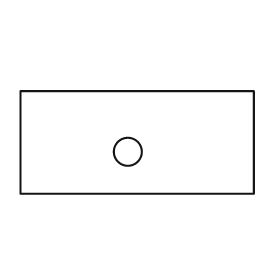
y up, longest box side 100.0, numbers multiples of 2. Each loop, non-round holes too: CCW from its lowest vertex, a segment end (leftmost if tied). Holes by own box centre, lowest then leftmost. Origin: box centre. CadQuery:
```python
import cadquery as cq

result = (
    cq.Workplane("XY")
    .moveTo(-50.0, -22.0)
    .lineTo(50.0, -22.0)
    .lineTo(50.0, 22.0)
    .lineTo(-50.0, 22.0)
    .close()
    .moveTo(-4.0, -4.0)
    .circle(6.0)
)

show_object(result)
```